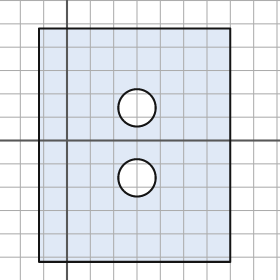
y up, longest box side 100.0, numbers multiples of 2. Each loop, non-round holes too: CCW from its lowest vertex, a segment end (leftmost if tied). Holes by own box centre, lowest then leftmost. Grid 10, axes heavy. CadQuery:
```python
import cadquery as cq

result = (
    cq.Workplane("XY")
    .moveTo(-12.0, -52.0)
    .lineTo(70.0, -52.0)
    .lineTo(70.0, 48.0)
    .lineTo(-12.0, 48.0)
    .close()
    .moveTo(30.0, -16.0)
    .circle(8.0)
    .moveTo(30.0, 14.0)
    .circle(8.0)
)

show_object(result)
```